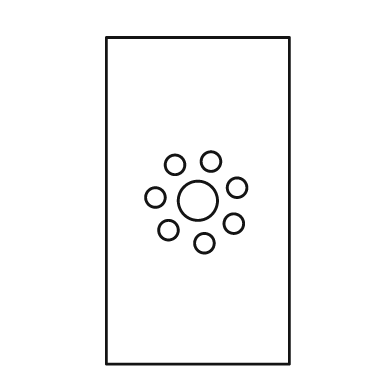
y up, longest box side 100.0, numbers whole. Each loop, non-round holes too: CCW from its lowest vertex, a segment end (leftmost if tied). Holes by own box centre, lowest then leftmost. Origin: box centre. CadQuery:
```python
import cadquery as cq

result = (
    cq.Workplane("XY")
    .moveTo(-28.0, -50.0)
    .lineTo(28.0, -50.0)
    .lineTo(28.0, 50.0)
    .lineTo(-28.0, 50.0)
    .close()
    .moveTo(2.0, -13.0)
    .circle(3.0)
    .moveTo(-9.0, -9.0)
    .circle(3.0)
    .moveTo(11.0, -7.0)
    .circle(3.0)
    .moveTo(0.0, 0.0)
    .circle(6.0)
    .moveTo(-13.0, 1.0)
    .circle(3.0)
    .moveTo(12.0, 4.0)
    .circle(3.0)
    .moveTo(-7.0, 11.0)
    .circle(3.0)
    .moveTo(4.0, 12.0)
    .circle(3.0)
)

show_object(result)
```